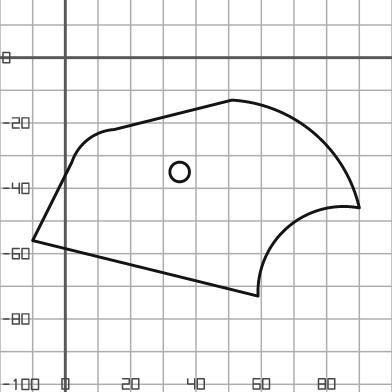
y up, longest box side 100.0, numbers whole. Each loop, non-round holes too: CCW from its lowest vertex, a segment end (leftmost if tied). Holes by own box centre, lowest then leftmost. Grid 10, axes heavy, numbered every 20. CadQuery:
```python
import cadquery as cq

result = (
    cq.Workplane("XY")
    .moveTo(59.0, -73.0)
    .threePointArc((68.0, -52.0), (90.0, -46.0))
    .threePointArc((76.0, -23.0), (51.0, -13.0))
    .lineTo(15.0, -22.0)
    .threePointArc((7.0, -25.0), (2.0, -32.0))
    .lineTo(-10.0, -56.0)
    .close()
    .moveTo(35.0, -35.0)
    .circle(3.0)
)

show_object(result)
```